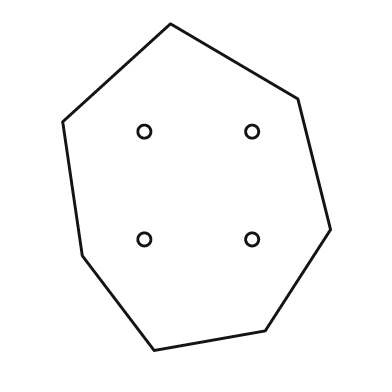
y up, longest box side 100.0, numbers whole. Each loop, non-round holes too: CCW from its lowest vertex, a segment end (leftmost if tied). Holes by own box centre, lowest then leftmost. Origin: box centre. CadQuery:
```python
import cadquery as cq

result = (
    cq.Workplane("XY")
    .moveTo(-13.0, -50.0)
    .lineTo(21.0, -44.0)
    .lineTo(41.0, -13.0)
    .lineTo(31.0, 27.0)
    .lineTo(-8.0, 50.0)
    .lineTo(-41.0, 20.0)
    .lineTo(-35.0, -21.0)
    .close()
    .moveTo(-16.0, -16.0)
    .circle(2.0)
    .moveTo(17.0, -16.0)
    .circle(2.0)
    .moveTo(-16.0, 17.0)
    .circle(2.0)
    .moveTo(17.0, 17.0)
    .circle(2.0)
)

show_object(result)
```